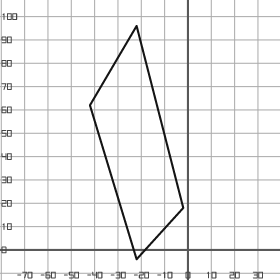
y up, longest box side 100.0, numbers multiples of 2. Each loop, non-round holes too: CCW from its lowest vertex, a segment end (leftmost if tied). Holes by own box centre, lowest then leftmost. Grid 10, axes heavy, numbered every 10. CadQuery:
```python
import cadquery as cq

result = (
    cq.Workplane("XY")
    .moveTo(-22.0, -4.0)
    .lineTo(-2.0, 18.0)
    .lineTo(-22.0, 96.0)
    .lineTo(-42.0, 62.0)
    .close()
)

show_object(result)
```